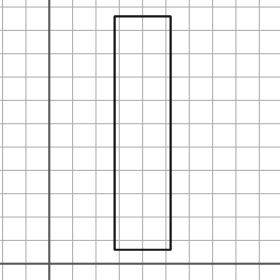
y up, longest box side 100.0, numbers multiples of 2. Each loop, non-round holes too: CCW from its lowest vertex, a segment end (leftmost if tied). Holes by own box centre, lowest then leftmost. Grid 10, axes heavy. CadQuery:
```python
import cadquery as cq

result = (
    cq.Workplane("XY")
    .moveTo(28.0, 6.0)
    .lineTo(52.0, 6.0)
    .lineTo(52.0, 106.0)
    .lineTo(28.0, 106.0)
    .close()
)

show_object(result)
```